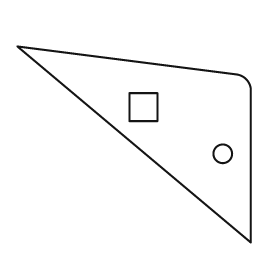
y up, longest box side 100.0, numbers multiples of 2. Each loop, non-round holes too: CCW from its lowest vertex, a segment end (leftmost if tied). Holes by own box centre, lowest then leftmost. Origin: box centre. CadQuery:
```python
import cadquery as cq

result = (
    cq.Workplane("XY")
    .moveTo(50.0, -42.0)
    .lineTo(50.0, 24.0)
    .threePointArc((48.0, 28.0), (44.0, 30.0))
    .lineTo(-50.0, 42.0)
    .close()
    .moveTo(38.0, -4.0)
    .circle(4.0)
    .moveTo(-2.0, 10.0)
    .lineTo(10.0, 10.0)
    .lineTo(10.0, 22.0)
    .lineTo(-2.0, 22.0)
    .close()
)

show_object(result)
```